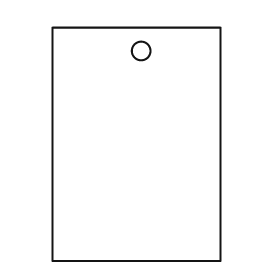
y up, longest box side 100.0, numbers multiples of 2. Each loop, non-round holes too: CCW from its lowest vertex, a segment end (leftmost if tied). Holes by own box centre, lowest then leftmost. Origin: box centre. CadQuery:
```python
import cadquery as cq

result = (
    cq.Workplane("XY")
    .moveTo(-36.0, -50.0)
    .lineTo(36.0, -50.0)
    .lineTo(36.0, 50.0)
    .lineTo(-36.0, 50.0)
    .close()
    .moveTo(2.0, 40.0)
    .circle(4.0)
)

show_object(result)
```